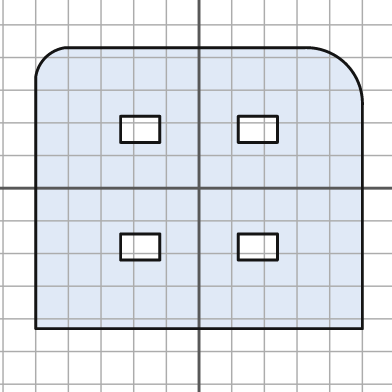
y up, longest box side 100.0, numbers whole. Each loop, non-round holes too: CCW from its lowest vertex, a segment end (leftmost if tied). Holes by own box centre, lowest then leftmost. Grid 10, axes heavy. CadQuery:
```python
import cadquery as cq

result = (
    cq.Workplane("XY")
    .moveTo(-50.0, -43.0)
    .lineTo(50.0, -43.0)
    .lineTo(50.0, 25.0)
    .threePointArc((45.0, 38.0), (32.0, 43.0))
    .lineTo(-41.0, 43.0)
    .threePointArc((-47.0, 40.0), (-50.0, 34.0))
    .close()
    .moveTo(-24.0, -22.0)
    .lineTo(-12.0, -22.0)
    .lineTo(-12.0, -14.0)
    .lineTo(-24.0, -14.0)
    .close()
    .moveTo(12.0, -22.0)
    .lineTo(24.0, -22.0)
    .lineTo(24.0, -14.0)
    .lineTo(12.0, -14.0)
    .close()
    .moveTo(-24.0, 14.0)
    .lineTo(-12.0, 14.0)
    .lineTo(-12.0, 22.0)
    .lineTo(-24.0, 22.0)
    .close()
    .moveTo(12.0, 14.0)
    .lineTo(24.0, 14.0)
    .lineTo(24.0, 22.0)
    .lineTo(12.0, 22.0)
    .close()
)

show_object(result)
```